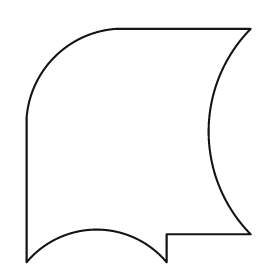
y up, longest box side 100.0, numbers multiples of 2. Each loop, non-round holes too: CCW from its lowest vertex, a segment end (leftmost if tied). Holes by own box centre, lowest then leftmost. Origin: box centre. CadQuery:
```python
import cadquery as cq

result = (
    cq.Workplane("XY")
    .moveTo(-48.0, -50.0)
    .threePointArc((-18.0, -36.0), (12.0, -50.0))
    .lineTo(12.0, -38.0)
    .lineTo(48.0, -38.0)
    .threePointArc((30.0, 6.0), (48.0, 50.0))
    .lineTo(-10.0, 50.0)
    .threePointArc((-36.0, 38.0), (-48.0, 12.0))
    .close()
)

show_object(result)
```